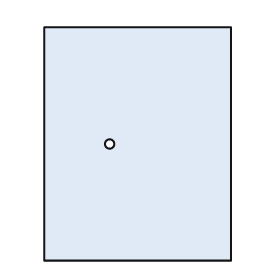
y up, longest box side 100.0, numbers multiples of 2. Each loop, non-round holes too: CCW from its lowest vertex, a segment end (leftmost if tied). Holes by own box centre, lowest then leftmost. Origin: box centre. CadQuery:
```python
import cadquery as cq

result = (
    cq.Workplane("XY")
    .moveTo(-40.0, -50.0)
    .lineTo(40.0, -50.0)
    .lineTo(40.0, 50.0)
    .lineTo(-40.0, 50.0)
    .close()
    .moveTo(-12.0, 0.0)
    .circle(2.0)
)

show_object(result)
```